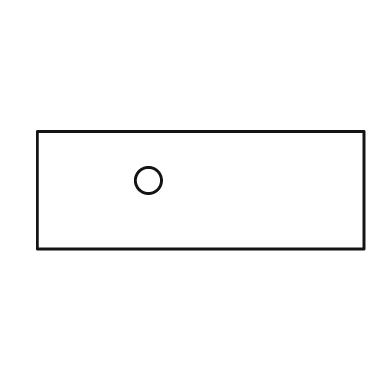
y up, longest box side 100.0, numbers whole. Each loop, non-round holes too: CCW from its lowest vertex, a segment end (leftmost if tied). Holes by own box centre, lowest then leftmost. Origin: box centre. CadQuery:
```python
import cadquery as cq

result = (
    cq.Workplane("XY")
    .moveTo(-50.0, -18.0)
    .lineTo(50.0, -18.0)
    .lineTo(50.0, 18.0)
    .lineTo(-50.0, 18.0)
    .close()
    .moveTo(-16.0, 3.0)
    .circle(4.0)
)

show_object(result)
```